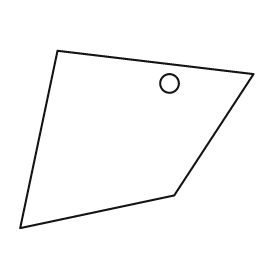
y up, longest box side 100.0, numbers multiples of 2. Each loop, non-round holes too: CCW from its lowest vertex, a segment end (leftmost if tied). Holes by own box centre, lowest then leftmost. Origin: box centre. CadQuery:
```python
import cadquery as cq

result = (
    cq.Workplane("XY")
    .moveTo(-50.0, -38.0)
    .lineTo(16.0, -24.0)
    .lineTo(50.0, 28.0)
    .lineTo(-34.0, 38.0)
    .close()
    .moveTo(14.0, 24.0)
    .circle(4.0)
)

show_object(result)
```